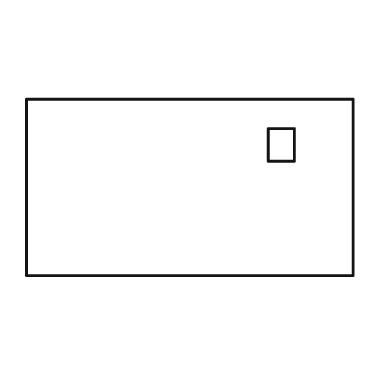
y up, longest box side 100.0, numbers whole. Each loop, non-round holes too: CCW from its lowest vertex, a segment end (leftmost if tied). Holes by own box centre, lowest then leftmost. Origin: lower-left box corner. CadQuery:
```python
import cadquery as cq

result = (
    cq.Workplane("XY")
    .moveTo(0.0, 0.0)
    .lineTo(100.0, 0.0)
    .lineTo(100.0, 54.0)
    .lineTo(0.0, 54.0)
    .close()
    .moveTo(74.0, 35.0)
    .lineTo(82.0, 35.0)
    .lineTo(82.0, 45.0)
    .lineTo(74.0, 45.0)
    .close()
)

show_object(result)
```